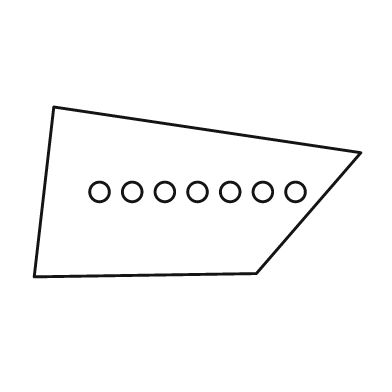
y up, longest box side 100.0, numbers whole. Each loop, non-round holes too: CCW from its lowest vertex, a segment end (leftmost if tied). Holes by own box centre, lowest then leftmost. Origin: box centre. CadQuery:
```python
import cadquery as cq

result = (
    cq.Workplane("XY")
    .moveTo(-50.0, -26.0)
    .lineTo(18.0, -25.0)
    .lineTo(50.0, 12.0)
    .lineTo(-44.0, 26.0)
    .close()
    .moveTo(-30.0, 0.0)
    .circle(3.0)
    .moveTo(-20.0, 0.0)
    .circle(3.0)
    .moveTo(-10.0, 0.0)
    .circle(3.0)
    .moveTo(0.0, 0.0)
    .circle(3.0)
    .moveTo(10.0, 0.0)
    .circle(3.0)
    .moveTo(20.0, 0.0)
    .circle(3.0)
    .moveTo(30.0, 0.0)
    .circle(3.0)
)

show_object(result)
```